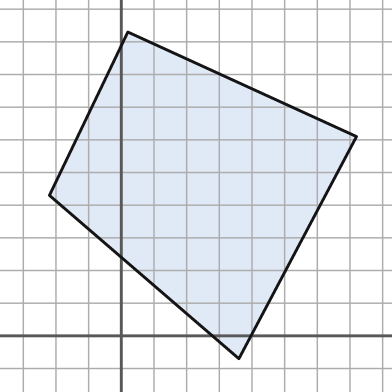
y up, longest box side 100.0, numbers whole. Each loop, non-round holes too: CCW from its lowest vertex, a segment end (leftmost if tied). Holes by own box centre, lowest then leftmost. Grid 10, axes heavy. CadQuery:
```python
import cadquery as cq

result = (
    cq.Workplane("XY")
    .moveTo(36.0, -7.0)
    .lineTo(72.0, 61.0)
    .lineTo(2.0, 93.0)
    .lineTo(-22.0, 43.0)
    .close()
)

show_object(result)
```